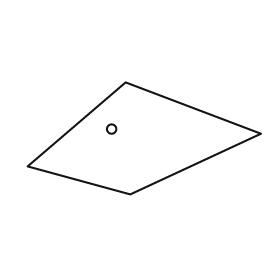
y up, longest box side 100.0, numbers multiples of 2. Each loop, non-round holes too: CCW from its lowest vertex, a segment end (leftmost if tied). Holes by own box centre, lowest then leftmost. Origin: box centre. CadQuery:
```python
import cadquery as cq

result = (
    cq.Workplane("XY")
    .moveTo(-6.0, -24.0)
    .lineTo(50.0, 2.0)
    .lineTo(-8.0, 24.0)
    .lineTo(-50.0, -12.0)
    .close()
    .moveTo(-14.0, 4.0)
    .circle(2.0)
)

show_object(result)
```